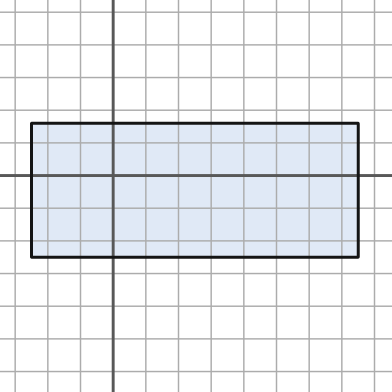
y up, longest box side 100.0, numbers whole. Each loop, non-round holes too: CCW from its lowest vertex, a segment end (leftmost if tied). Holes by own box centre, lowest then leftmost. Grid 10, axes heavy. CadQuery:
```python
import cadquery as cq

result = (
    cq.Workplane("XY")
    .moveTo(-25.0, -25.0)
    .lineTo(75.0, -25.0)
    .lineTo(75.0, 16.0)
    .lineTo(-25.0, 16.0)
    .close()
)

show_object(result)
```